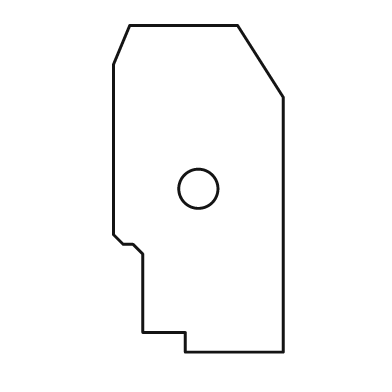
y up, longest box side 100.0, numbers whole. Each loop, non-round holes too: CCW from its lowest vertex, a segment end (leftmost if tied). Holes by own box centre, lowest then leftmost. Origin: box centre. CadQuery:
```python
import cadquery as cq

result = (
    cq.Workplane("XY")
    .moveTo(-4.0, -50.0)
    .lineTo(26.0, -50.0)
    .lineTo(26.0, 28.0)
    .lineTo(12.0, 50.0)
    .lineTo(-21.0, 50.0)
    .lineTo(-26.0, 38.0)
    .lineTo(-26.0, -14.0)
    .lineTo(-23.0, -17.0)
    .lineTo(-20.0, -17.0)
    .lineTo(-17.0, -20.0)
    .lineTo(-17.0, -44.0)
    .lineTo(-4.0, -44.0)
    .close()
    .moveTo(0.0, 0.0)
    .circle(6.0)
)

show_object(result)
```